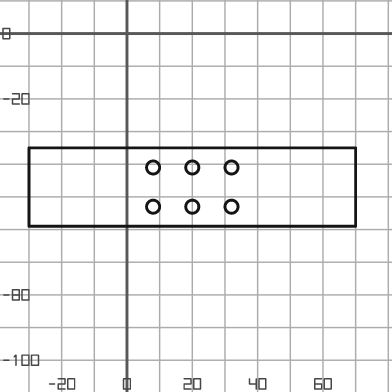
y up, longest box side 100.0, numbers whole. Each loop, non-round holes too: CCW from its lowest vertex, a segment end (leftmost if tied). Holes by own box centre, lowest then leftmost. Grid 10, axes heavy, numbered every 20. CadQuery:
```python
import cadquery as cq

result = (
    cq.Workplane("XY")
    .moveTo(-30.0, -59.0)
    .lineTo(70.0, -59.0)
    .lineTo(70.0, -35.0)
    .lineTo(-30.0, -35.0)
    .close()
    .moveTo(8.0, -53.0)
    .circle(2.0)
    .moveTo(20.0, -53.0)
    .circle(2.0)
    .moveTo(32.0, -53.0)
    .circle(2.0)
    .moveTo(8.0, -41.0)
    .circle(2.0)
    .moveTo(20.0, -41.0)
    .circle(2.0)
    .moveTo(32.0, -41.0)
    .circle(2.0)
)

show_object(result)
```